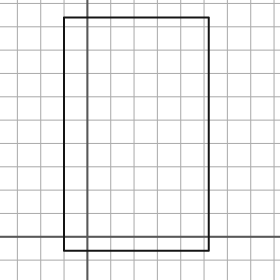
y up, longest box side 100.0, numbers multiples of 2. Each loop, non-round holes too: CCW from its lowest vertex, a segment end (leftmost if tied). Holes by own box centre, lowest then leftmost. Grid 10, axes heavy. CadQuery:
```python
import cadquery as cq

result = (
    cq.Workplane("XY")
    .moveTo(-10.0, -6.0)
    .lineTo(52.0, -6.0)
    .lineTo(52.0, 94.0)
    .lineTo(-10.0, 94.0)
    .close()
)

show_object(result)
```